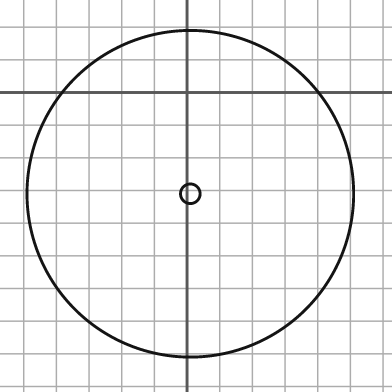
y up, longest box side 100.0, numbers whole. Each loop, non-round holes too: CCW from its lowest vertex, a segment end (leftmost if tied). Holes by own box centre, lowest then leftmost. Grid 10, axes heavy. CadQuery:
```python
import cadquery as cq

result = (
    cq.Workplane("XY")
    .moveTo(1.0, -31.0)
    .circle(50.0)
    .moveTo(1.0, -31.0)
    .circle(3.0)
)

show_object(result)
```